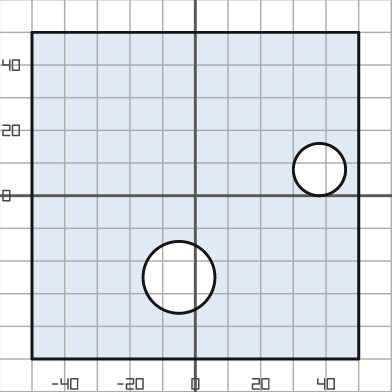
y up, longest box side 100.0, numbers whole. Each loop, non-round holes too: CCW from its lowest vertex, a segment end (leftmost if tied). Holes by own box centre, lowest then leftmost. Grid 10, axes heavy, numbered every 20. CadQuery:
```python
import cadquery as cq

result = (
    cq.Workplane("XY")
    .moveTo(-50.0, -50.0)
    .lineTo(50.0, -50.0)
    .lineTo(50.0, 50.0)
    .lineTo(-50.0, 50.0)
    .close()
    .moveTo(-5.0, -25.0)
    .circle(11.0)
    .moveTo(38.0, 8.0)
    .circle(8.0)
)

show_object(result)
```